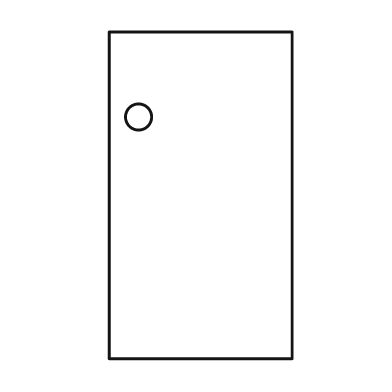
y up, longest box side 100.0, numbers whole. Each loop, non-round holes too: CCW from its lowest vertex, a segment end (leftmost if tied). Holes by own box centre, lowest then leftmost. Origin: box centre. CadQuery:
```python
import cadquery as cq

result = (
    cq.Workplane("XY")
    .moveTo(-28.0, -50.0)
    .lineTo(28.0, -50.0)
    .lineTo(28.0, 50.0)
    .lineTo(-28.0, 50.0)
    .close()
    .moveTo(-19.0, 24.0)
    .circle(4.0)
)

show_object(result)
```